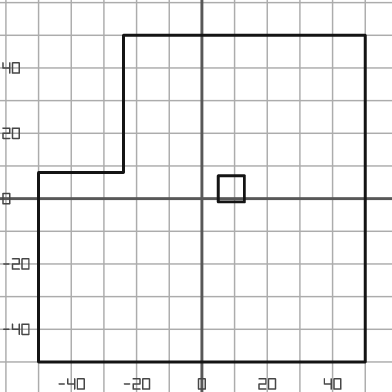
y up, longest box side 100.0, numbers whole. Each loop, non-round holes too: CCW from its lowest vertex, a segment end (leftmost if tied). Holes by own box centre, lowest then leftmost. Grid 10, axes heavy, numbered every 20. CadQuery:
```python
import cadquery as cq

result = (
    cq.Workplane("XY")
    .moveTo(-50.0, -50.0)
    .lineTo(50.0, -50.0)
    .lineTo(50.0, 50.0)
    .lineTo(-24.0, 50.0)
    .lineTo(-24.0, 8.0)
    .lineTo(-50.0, 8.0)
    .close()
    .moveTo(5.0, -1.0)
    .lineTo(13.0, -1.0)
    .lineTo(13.0, 7.0)
    .lineTo(5.0, 7.0)
    .close()
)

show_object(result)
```